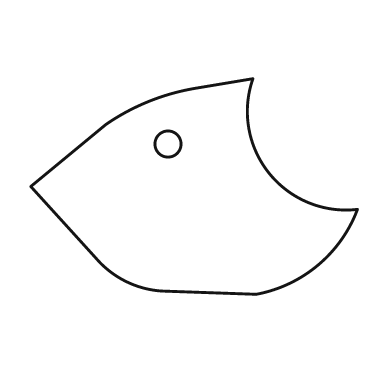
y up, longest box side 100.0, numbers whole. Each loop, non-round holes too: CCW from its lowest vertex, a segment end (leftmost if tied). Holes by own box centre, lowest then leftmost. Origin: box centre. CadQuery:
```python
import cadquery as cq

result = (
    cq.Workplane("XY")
    .moveTo(19.0, -33.0)
    .threePointArc((38.0, -24.0), (50.0, -7.0))
    .threePointArc((23.0, 4.0), (18.0, 33.0))
    .lineTo(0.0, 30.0)
    .threePointArc((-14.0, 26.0), (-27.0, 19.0))
    .lineTo(-50.0, 0.0)
    .lineTo(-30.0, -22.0)
    .threePointArc((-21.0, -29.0), (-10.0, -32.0))
    .close()
    .moveTo(-8.0, 13.0)
    .circle(4.0)
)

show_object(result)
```